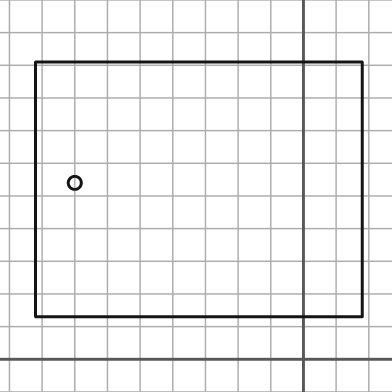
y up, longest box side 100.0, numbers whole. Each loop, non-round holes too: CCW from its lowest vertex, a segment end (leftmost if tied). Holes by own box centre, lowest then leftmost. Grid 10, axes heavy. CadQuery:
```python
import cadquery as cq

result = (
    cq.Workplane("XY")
    .moveTo(-82.0, 13.0)
    .lineTo(18.0, 13.0)
    .lineTo(18.0, 91.0)
    .lineTo(-82.0, 91.0)
    .close()
    .moveTo(-70.0, 54.0)
    .circle(2.0)
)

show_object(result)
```